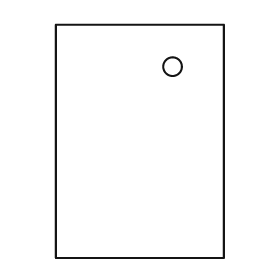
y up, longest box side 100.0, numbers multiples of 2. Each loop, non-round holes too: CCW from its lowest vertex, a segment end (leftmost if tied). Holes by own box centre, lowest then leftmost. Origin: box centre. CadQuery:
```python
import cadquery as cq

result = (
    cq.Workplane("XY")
    .moveTo(-36.0, -50.0)
    .lineTo(36.0, -50.0)
    .lineTo(36.0, 50.0)
    .lineTo(-36.0, 50.0)
    .close()
    .moveTo(14.0, 32.0)
    .circle(4.0)
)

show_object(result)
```